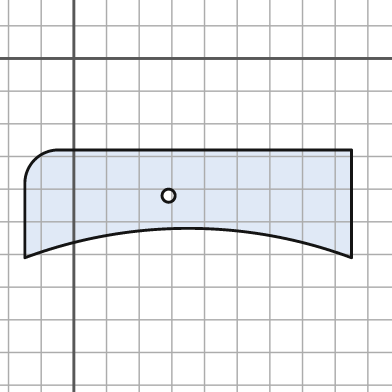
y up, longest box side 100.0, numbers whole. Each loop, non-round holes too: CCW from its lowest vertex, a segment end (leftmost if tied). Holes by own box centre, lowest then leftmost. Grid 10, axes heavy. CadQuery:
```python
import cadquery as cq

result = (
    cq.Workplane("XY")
    .moveTo(-15.0, -61.0)
    .threePointArc((35.0, -52.0), (85.0, -61.0))
    .lineTo(85.0, -28.0)
    .lineTo(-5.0, -28.0)
    .threePointArc((-12.0, -31.0), (-15.0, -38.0))
    .close()
    .moveTo(29.0, -42.0)
    .circle(2.0)
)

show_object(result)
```